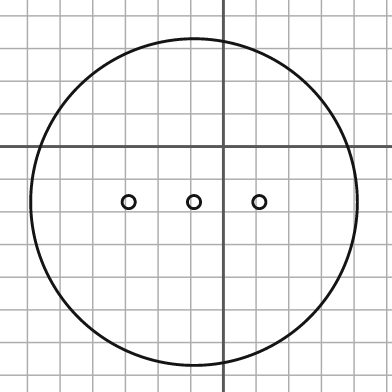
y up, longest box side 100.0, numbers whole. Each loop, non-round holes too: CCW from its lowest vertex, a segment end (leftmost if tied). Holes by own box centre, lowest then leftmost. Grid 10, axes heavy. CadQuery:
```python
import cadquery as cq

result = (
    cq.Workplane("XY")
    .moveTo(-9.0, -17.0)
    .circle(50.0)
    .moveTo(-29.0, -17.0)
    .circle(2.0)
    .moveTo(-9.0, -17.0)
    .circle(2.0)
    .moveTo(11.0, -17.0)
    .circle(2.0)
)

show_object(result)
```